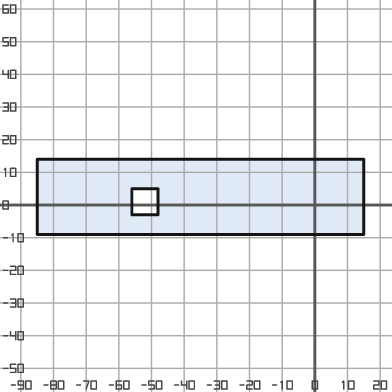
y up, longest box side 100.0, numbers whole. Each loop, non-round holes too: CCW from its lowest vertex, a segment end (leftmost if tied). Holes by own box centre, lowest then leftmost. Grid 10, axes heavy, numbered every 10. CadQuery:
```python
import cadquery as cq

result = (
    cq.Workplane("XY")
    .moveTo(-85.0, -9.0)
    .lineTo(15.0, -9.0)
    .lineTo(15.0, 14.0)
    .lineTo(-85.0, 14.0)
    .close()
    .moveTo(-56.0, -3.0)
    .lineTo(-48.0, -3.0)
    .lineTo(-48.0, 5.0)
    .lineTo(-56.0, 5.0)
    .close()
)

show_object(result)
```